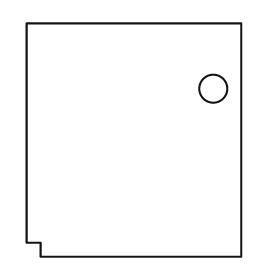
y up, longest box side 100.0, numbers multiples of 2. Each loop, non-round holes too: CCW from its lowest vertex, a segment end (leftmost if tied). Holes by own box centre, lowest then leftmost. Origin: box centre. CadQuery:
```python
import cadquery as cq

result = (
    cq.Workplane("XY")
    .moveTo(-40.0, -50.0)
    .lineTo(46.0, -50.0)
    .lineTo(46.0, 50.0)
    .lineTo(-46.0, 50.0)
    .lineTo(-46.0, -44.0)
    .lineTo(-40.0, -44.0)
    .close()
    .moveTo(34.0, 22.0)
    .circle(6.0)
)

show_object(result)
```